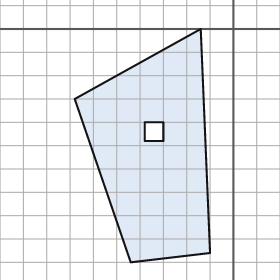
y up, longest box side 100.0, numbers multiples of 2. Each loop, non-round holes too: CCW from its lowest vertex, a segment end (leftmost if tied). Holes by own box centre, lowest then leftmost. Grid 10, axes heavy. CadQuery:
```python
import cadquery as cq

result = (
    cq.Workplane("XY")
    .moveTo(-44.0, -100.0)
    .lineTo(-10.0, -96.0)
    .lineTo(-14.0, 0.0)
    .lineTo(-68.0, -30.0)
    .close()
    .moveTo(-38.0, -48.0)
    .lineTo(-30.0, -48.0)
    .lineTo(-30.0, -40.0)
    .lineTo(-38.0, -40.0)
    .close()
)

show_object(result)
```